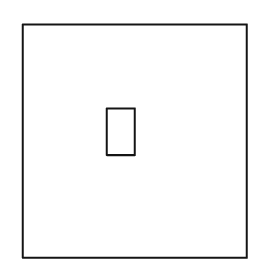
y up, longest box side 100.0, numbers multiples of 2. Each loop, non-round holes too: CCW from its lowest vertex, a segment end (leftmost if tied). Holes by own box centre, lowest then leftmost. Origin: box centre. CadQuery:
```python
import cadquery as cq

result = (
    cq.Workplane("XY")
    .moveTo(-48.0, -50.0)
    .lineTo(48.0, -50.0)
    .lineTo(48.0, 50.0)
    .lineTo(-48.0, 50.0)
    .close()
    .moveTo(-12.0, -6.0)
    .lineTo(0.0, -6.0)
    .lineTo(0.0, 14.0)
    .lineTo(-12.0, 14.0)
    .close()
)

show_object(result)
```